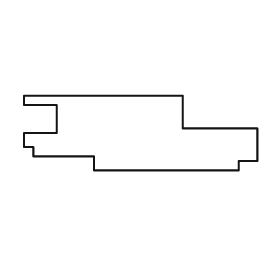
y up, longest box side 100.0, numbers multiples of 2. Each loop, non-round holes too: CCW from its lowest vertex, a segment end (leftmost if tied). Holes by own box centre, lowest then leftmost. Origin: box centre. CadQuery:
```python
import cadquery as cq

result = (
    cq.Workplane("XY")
    .moveTo(-20.0, -16.0)
    .lineTo(42.0, -16.0)
    .lineTo(42.0, -12.0)
    .lineTo(50.0, -12.0)
    .lineTo(50.0, 2.0)
    .lineTo(18.0, 2.0)
    .lineTo(18.0, 16.0)
    .lineTo(-50.0, 16.0)
    .lineTo(-50.0, 12.0)
    .lineTo(-36.0, 12.0)
    .lineTo(-36.0, 0.0)
    .lineTo(-50.0, 0.0)
    .lineTo(-50.0, -6.0)
    .lineTo(-46.0, -6.0)
    .lineTo(-46.0, -10.0)
    .lineTo(-20.0, -10.0)
    .close()
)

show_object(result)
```